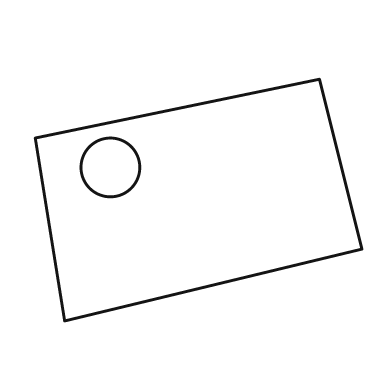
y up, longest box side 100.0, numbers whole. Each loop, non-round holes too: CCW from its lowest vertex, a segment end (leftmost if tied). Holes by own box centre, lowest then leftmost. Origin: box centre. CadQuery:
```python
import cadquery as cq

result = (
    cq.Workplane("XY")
    .moveTo(-41.0, -37.0)
    .lineTo(50.0, -15.0)
    .lineTo(37.0, 37.0)
    .lineTo(-50.0, 19.0)
    .close()
    .moveTo(-27.0, 10.0)
    .circle(9.0)
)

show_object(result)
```